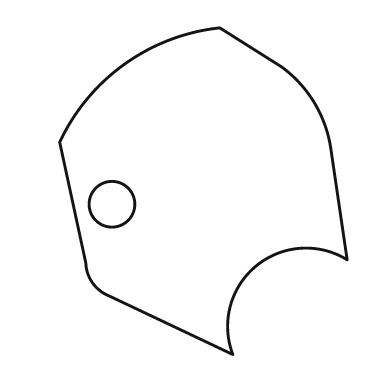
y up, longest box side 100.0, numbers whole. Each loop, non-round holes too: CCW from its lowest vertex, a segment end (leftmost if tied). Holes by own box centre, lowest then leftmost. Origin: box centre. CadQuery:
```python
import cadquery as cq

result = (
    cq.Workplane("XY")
    .moveTo(9.0, -50.0)
    .threePointArc((16.0, -23.0), (44.0, -21.0))
    .lineTo(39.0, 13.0)
    .threePointArc((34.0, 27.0), (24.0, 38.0))
    .lineTo(5.0, 50.0)
    .threePointArc((-24.0, 39.0), (-44.0, 15.0))
    .lineTo(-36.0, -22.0)
    .threePointArc((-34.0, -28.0), (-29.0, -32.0))
    .close()
    .moveTo(-28.0, -4.0)
    .circle(7.0)
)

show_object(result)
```